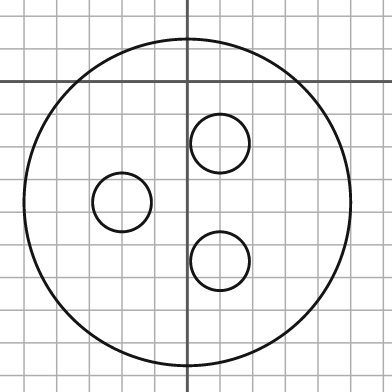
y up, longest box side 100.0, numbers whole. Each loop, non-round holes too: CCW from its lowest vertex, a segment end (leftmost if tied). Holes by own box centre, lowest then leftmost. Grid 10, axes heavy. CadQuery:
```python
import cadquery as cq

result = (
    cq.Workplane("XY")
    .moveTo(0.0, -37.0)
    .circle(50.0)
    .moveTo(10.0, -55.0)
    .circle(9.0)
    .moveTo(-20.0, -37.0)
    .circle(9.0)
    .moveTo(10.0, -19.0)
    .circle(9.0)
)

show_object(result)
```